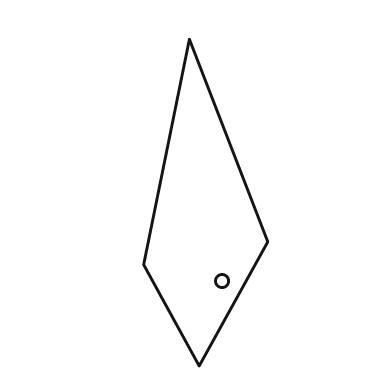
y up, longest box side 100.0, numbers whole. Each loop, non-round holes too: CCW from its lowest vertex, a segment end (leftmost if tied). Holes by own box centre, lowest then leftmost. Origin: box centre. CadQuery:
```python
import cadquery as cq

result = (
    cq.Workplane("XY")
    .moveTo(-2.0, -50.0)
    .lineTo(19.0, -12.0)
    .lineTo(-5.0, 50.0)
    .lineTo(-19.0, -19.0)
    .close()
    .moveTo(5.0, -24.0)
    .circle(2.0)
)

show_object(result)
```